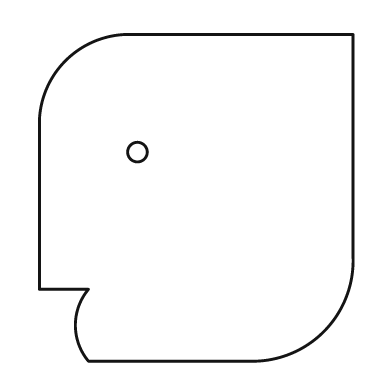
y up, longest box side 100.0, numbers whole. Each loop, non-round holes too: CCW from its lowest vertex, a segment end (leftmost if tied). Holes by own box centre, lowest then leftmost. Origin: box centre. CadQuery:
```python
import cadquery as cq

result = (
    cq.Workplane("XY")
    .moveTo(-33.0, -50.0)
    .lineTo(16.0, -50.0)
    .threePointArc((39.0, -41.0), (48.0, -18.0))
    .lineTo(48.0, 50.0)
    .lineTo(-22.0, 50.0)
    .threePointArc((-40.0, 42.0), (-48.0, 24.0))
    .lineTo(-48.0, -28.0)
    .lineTo(-33.0, -28.0)
    .threePointArc((-37.0, -39.0), (-33.0, -50.0))
    .close()
    .moveTo(-18.0, 14.0)
    .circle(3.0)
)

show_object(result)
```